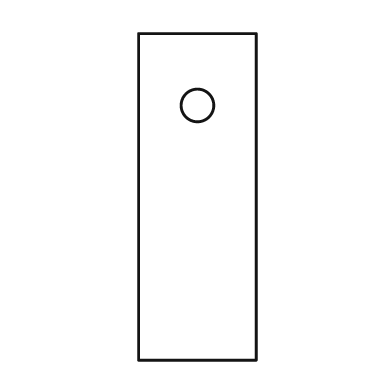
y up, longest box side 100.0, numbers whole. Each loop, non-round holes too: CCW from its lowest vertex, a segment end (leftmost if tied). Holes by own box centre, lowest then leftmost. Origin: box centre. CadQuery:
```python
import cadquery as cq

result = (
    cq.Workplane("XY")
    .moveTo(-18.0, -50.0)
    .lineTo(18.0, -50.0)
    .lineTo(18.0, 50.0)
    .lineTo(-18.0, 50.0)
    .close()
    .moveTo(0.0, 28.0)
    .circle(5.0)
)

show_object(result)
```